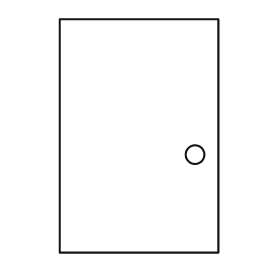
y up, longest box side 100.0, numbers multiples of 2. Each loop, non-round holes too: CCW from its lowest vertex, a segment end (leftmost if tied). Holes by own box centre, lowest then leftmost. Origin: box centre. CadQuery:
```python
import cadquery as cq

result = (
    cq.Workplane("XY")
    .moveTo(-34.0, -50.0)
    .lineTo(34.0, -50.0)
    .lineTo(34.0, 50.0)
    .lineTo(-34.0, 50.0)
    .close()
    .moveTo(24.0, -8.0)
    .circle(4.0)
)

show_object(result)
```